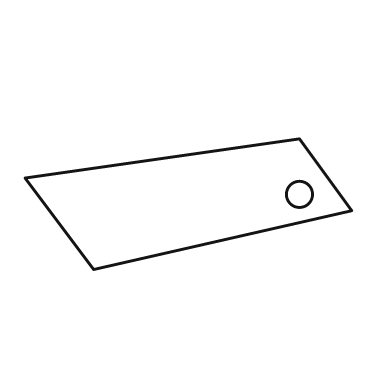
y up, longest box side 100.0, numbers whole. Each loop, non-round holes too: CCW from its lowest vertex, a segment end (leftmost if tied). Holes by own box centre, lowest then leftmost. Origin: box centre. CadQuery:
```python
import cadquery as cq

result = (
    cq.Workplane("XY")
    .moveTo(-29.0, -20.0)
    .lineTo(50.0, -2.0)
    .lineTo(34.0, 20.0)
    .lineTo(-50.0, 8.0)
    .close()
    .moveTo(34.0, 3.0)
    .circle(4.0)
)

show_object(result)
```